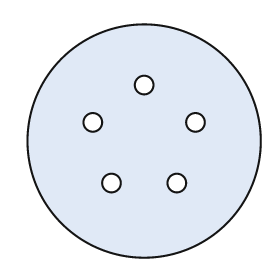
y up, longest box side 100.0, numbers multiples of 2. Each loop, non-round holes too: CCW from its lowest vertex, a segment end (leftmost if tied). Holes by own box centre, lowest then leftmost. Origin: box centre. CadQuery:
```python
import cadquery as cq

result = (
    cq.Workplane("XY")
    .moveTo(0.0, 0.0)
    .circle(50.0)
    .moveTo(-14.0, -18.0)
    .circle(4.0)
    .moveTo(14.0, -18.0)
    .circle(4.0)
    .moveTo(-22.0, 8.0)
    .circle(4.0)
    .moveTo(22.0, 8.0)
    .circle(4.0)
    .moveTo(0.0, 24.0)
    .circle(4.0)
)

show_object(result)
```